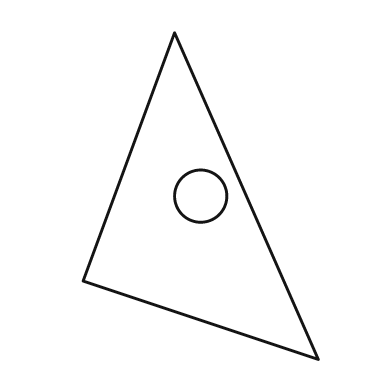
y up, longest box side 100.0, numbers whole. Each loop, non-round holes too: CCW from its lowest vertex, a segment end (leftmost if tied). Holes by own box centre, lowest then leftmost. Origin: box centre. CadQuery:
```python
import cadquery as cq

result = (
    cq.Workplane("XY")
    .moveTo(36.0, -50.0)
    .lineTo(-8.0, 50.0)
    .lineTo(-36.0, -26.0)
    .close()
    .moveTo(0.0, 0.0)
    .circle(8.0)
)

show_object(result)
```